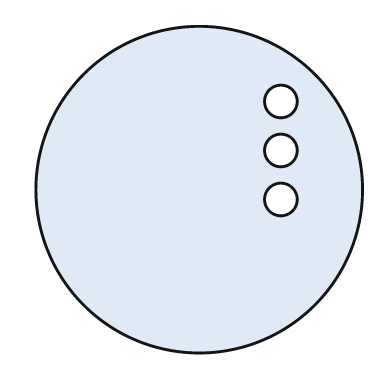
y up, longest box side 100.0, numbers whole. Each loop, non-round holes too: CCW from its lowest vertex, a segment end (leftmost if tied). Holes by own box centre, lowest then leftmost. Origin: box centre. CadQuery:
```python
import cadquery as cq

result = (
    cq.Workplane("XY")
    .moveTo(0.0, 0.0)
    .circle(50.0)
    .moveTo(25.0, -3.0)
    .circle(5.0)
    .moveTo(25.0, 12.0)
    .circle(5.0)
    .moveTo(25.0, 27.0)
    .circle(5.0)
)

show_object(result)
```